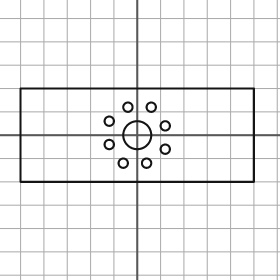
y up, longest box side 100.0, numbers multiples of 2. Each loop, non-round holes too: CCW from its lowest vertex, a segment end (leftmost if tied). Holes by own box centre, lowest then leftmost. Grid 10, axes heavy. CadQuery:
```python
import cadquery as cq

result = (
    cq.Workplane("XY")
    .moveTo(-50.0, -20.0)
    .lineTo(50.0, -20.0)
    .lineTo(50.0, 20.0)
    .lineTo(-50.0, 20.0)
    .close()
    .moveTo(-6.0, -12.0)
    .circle(2.0)
    .moveTo(4.0, -12.0)
    .circle(2.0)
    .moveTo(12.0, -6.0)
    .circle(2.0)
    .moveTo(-12.0, -4.0)
    .circle(2.0)
    .moveTo(0.0, 0.0)
    .circle(6.0)
    .moveTo(12.0, 4.0)
    .circle(2.0)
    .moveTo(-12.0, 6.0)
    .circle(2.0)
    .moveTo(-4.0, 12.0)
    .circle(2.0)
    .moveTo(6.0, 12.0)
    .circle(2.0)
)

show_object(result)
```